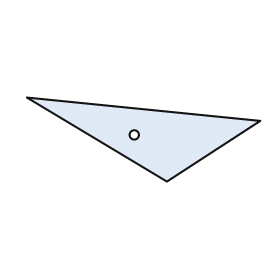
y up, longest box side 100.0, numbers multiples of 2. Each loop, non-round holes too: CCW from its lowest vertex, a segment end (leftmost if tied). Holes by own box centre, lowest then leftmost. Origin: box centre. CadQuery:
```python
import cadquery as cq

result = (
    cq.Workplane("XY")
    .moveTo(10.0, -18.0)
    .lineTo(50.0, 8.0)
    .lineTo(-50.0, 18.0)
    .close()
    .moveTo(-4.0, 2.0)
    .circle(2.0)
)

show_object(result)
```